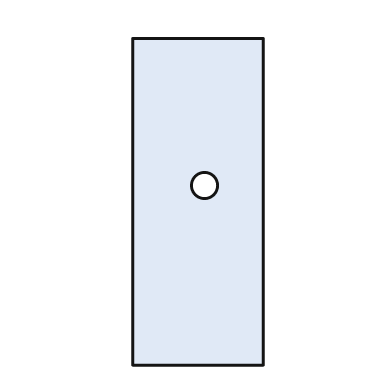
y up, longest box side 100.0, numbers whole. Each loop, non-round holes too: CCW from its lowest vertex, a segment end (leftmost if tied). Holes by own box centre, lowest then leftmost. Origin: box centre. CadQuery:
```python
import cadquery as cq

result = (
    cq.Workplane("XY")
    .moveTo(-20.0, -50.0)
    .lineTo(20.0, -50.0)
    .lineTo(20.0, 50.0)
    .lineTo(-20.0, 50.0)
    .close()
    .moveTo(2.0, 5.0)
    .circle(4.0)
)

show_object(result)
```